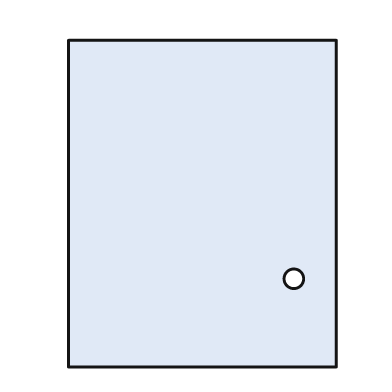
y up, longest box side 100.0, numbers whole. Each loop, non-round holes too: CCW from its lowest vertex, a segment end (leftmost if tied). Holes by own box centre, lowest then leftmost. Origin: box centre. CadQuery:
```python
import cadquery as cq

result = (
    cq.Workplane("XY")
    .moveTo(-41.0, -50.0)
    .lineTo(41.0, -50.0)
    .lineTo(41.0, 50.0)
    .lineTo(-41.0, 50.0)
    .close()
    .moveTo(28.0, -23.0)
    .circle(3.0)
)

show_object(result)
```